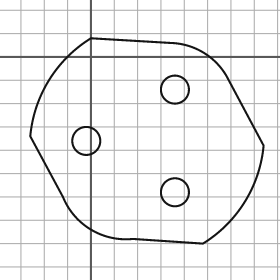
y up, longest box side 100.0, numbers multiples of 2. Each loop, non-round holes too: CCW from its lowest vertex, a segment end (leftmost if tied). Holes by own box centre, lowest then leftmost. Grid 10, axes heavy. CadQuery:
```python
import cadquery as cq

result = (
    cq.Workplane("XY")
    .moveTo(48.0, -80.0)
    .threePointArc((66.0, -62.0), (74.0, -38.0))
    .lineTo(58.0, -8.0)
    .threePointArc((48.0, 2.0), (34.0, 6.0))
    .lineTo(0.0, 8.0)
    .threePointArc((-18.0, -10.0), (-26.0, -34.0))
    .lineTo(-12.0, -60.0)
    .threePointArc((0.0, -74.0), (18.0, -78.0))
    .close()
    .moveTo(36.0, -58.0)
    .circle(6.0)
    .moveTo(-2.0, -36.0)
    .circle(6.0)
    .moveTo(36.0, -14.0)
    .circle(6.0)
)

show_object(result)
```